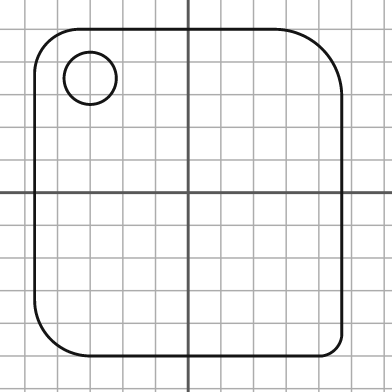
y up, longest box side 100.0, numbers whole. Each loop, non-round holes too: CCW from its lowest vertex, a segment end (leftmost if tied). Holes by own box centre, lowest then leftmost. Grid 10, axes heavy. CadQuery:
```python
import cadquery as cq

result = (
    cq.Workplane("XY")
    .moveTo(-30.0, -50.0)
    .lineTo(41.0, -50.0)
    .threePointArc((45.0, -48.0), (47.0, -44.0))
    .lineTo(47.0, 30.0)
    .threePointArc((41.0, 44.0), (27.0, 50.0))
    .lineTo(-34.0, 50.0)
    .threePointArc((-43.0, 46.0), (-47.0, 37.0))
    .lineTo(-47.0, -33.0)
    .threePointArc((-42.0, -45.0), (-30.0, -50.0))
    .close()
    .moveTo(-30.0, 35.0)
    .circle(8.0)
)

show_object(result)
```